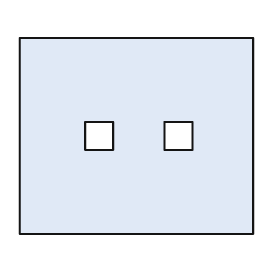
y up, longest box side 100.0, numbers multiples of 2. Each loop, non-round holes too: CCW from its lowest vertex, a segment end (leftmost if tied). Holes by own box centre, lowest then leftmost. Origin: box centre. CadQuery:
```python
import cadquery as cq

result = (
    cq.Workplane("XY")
    .moveTo(-50.0, -42.0)
    .lineTo(50.0, -42.0)
    .lineTo(50.0, 42.0)
    .lineTo(-50.0, 42.0)
    .close()
    .moveTo(-22.0, -6.0)
    .lineTo(-10.0, -6.0)
    .lineTo(-10.0, 6.0)
    .lineTo(-22.0, 6.0)
    .close()
    .moveTo(12.0, -6.0)
    .lineTo(24.0, -6.0)
    .lineTo(24.0, 6.0)
    .lineTo(12.0, 6.0)
    .close()
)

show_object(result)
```